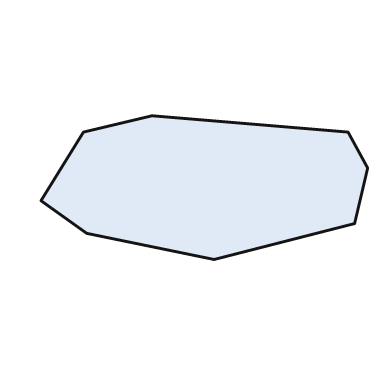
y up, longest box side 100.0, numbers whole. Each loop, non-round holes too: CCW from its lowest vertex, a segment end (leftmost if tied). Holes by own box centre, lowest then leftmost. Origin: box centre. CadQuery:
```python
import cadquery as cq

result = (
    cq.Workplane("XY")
    .moveTo(3.0, -22.0)
    .lineTo(46.0, -11.0)
    .lineTo(50.0, 6.0)
    .lineTo(44.0, 17.0)
    .lineTo(-16.0, 22.0)
    .lineTo(-37.0, 17.0)
    .lineTo(-50.0, -4.0)
    .lineTo(-36.0, -14.0)
    .close()
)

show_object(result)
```